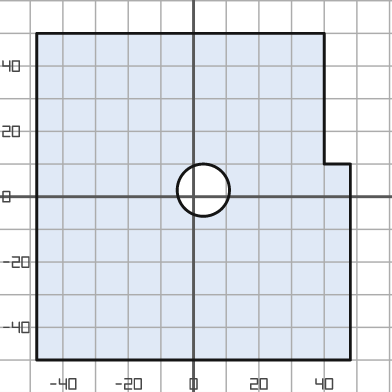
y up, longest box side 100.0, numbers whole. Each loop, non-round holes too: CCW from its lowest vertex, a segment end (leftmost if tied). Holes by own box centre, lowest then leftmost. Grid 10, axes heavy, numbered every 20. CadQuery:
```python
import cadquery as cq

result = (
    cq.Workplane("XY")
    .moveTo(-48.0, -50.0)
    .lineTo(48.0, -50.0)
    .lineTo(48.0, 10.0)
    .lineTo(40.0, 10.0)
    .lineTo(40.0, 50.0)
    .lineTo(-48.0, 50.0)
    .close()
    .moveTo(3.0, 2.0)
    .circle(8.0)
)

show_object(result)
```